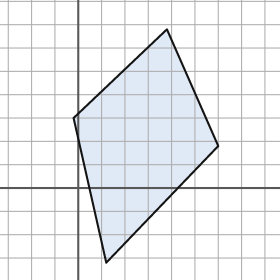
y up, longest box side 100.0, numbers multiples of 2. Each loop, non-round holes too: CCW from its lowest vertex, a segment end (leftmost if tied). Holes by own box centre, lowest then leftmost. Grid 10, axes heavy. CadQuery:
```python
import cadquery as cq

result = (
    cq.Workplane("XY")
    .moveTo(12.0, -32.0)
    .lineTo(60.0, 18.0)
    .lineTo(38.0, 68.0)
    .lineTo(-2.0, 30.0)
    .close()
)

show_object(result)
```